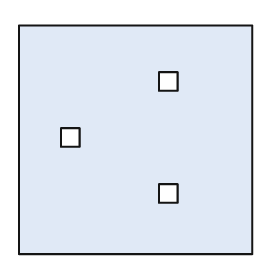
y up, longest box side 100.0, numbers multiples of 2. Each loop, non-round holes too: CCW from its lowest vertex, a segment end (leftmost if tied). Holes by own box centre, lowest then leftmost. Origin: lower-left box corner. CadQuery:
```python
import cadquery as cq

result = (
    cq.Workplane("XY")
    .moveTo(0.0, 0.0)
    .lineTo(100.0, 0.0)
    .lineTo(100.0, 98.0)
    .lineTo(0.0, 98.0)
    .close()
    .moveTo(60.0, 22.0)
    .lineTo(68.0, 22.0)
    .lineTo(68.0, 30.0)
    .lineTo(60.0, 30.0)
    .close()
    .moveTo(18.0, 46.0)
    .lineTo(26.0, 46.0)
    .lineTo(26.0, 54.0)
    .lineTo(18.0, 54.0)
    .close()
    .moveTo(60.0, 70.0)
    .lineTo(68.0, 70.0)
    .lineTo(68.0, 78.0)
    .lineTo(60.0, 78.0)
    .close()
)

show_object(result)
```